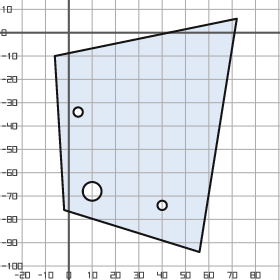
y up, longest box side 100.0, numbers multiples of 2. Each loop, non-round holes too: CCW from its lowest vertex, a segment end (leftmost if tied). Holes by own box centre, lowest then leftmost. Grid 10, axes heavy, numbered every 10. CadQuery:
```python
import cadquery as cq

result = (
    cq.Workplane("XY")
    .moveTo(56.0, -94.0)
    .lineTo(72.0, 6.0)
    .lineTo(-6.0, -10.0)
    .lineTo(-2.0, -76.0)
    .close()
    .moveTo(40.0, -74.0)
    .circle(2.0)
    .moveTo(10.0, -68.0)
    .circle(4.0)
    .moveTo(4.0, -34.0)
    .circle(2.0)
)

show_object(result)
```